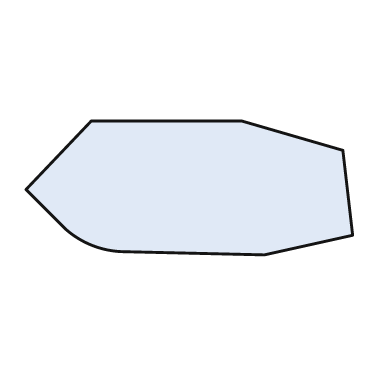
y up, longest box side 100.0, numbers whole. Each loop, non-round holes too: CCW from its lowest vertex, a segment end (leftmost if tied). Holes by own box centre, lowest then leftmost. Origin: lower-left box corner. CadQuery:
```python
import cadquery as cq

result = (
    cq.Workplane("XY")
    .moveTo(73.0, 0.0)
    .lineTo(100.0, 6.0)
    .lineTo(97.0, 32.0)
    .lineTo(66.0, 41.0)
    .lineTo(20.0, 41.0)
    .lineTo(0.0, 20.0)
    .lineTo(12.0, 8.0)
    .threePointArc((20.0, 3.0), (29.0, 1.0))
    .close()
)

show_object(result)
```